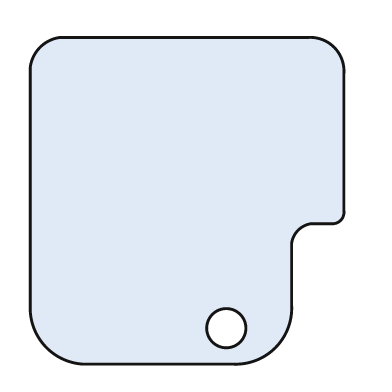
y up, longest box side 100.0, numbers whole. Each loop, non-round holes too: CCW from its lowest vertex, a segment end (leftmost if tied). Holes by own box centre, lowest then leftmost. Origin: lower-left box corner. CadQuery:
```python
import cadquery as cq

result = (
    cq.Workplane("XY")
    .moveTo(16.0, 0.0)
    .lineTo(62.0, 0.0)
    .threePointArc((75.0, 5.0), (80.0, 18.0))
    .lineTo(80.0, 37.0)
    .threePointArc((82.0, 41.0), (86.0, 43.0))
    .lineTo(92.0, 43.0)
    .threePointArc((95.0, 44.0), (96.0, 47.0))
    .lineTo(96.0, 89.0)
    .threePointArc((93.0, 97.0), (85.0, 100.0))
    .lineTo(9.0, 100.0)
    .threePointArc((3.0, 97.0), (0.0, 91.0))
    .lineTo(0.0, 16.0)
    .threePointArc((5.0, 5.0), (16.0, 0.0))
    .close()
    .moveTo(60.0, 11.0)
    .circle(6.0)
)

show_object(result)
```